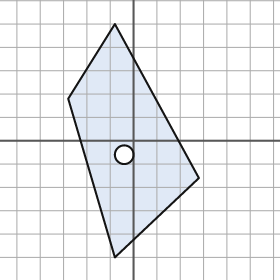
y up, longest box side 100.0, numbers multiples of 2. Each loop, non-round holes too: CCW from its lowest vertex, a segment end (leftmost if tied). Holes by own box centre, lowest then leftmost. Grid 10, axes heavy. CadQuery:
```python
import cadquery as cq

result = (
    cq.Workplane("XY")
    .moveTo(-8.0, -50.0)
    .lineTo(28.0, -16.0)
    .lineTo(-8.0, 50.0)
    .lineTo(-28.0, 18.0)
    .close()
    .moveTo(-4.0, -6.0)
    .circle(4.0)
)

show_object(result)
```